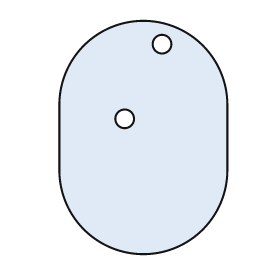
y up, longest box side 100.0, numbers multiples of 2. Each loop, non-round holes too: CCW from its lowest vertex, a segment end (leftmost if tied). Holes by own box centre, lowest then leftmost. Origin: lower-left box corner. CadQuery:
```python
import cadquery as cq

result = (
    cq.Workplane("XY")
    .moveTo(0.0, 36.0)
    .threePointArc((36.0, 0.0), (72.0, 36.0))
    .lineTo(72.0, 64.0)
    .threePointArc((36.0, 100.0), (0.0, 64.0))
    .close()
    .moveTo(28.0, 58.0)
    .circle(4.0)
    .moveTo(44.0, 90.0)
    .circle(4.0)
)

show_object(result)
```